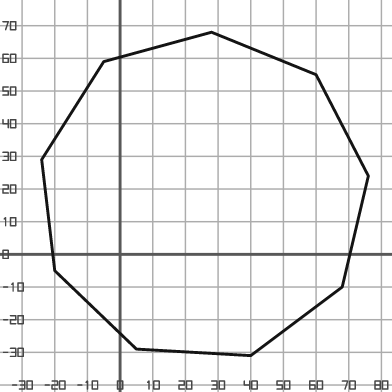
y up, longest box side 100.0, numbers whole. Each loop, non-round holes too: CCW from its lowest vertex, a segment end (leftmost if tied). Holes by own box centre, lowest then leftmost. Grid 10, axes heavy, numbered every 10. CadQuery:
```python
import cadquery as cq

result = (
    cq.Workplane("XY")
    .moveTo(40.0, -31.0)
    .lineTo(68.0, -10.0)
    .lineTo(76.0, 24.0)
    .lineTo(60.0, 55.0)
    .lineTo(28.0, 68.0)
    .lineTo(-5.0, 59.0)
    .lineTo(-24.0, 29.0)
    .lineTo(-20.0, -5.0)
    .lineTo(5.0, -29.0)
    .close()
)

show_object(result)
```